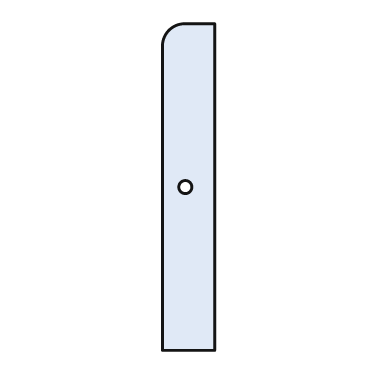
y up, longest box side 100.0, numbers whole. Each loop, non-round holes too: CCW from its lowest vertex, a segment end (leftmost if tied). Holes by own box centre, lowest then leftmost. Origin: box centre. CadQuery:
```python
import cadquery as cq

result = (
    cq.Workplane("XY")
    .moveTo(-8.0, -50.0)
    .lineTo(8.0, -50.0)
    .lineTo(8.0, 50.0)
    .lineTo(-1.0, 50.0)
    .threePointArc((-6.0, 48.0), (-8.0, 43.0))
    .close()
    .moveTo(-1.0, 0.0)
    .circle(2.0)
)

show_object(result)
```